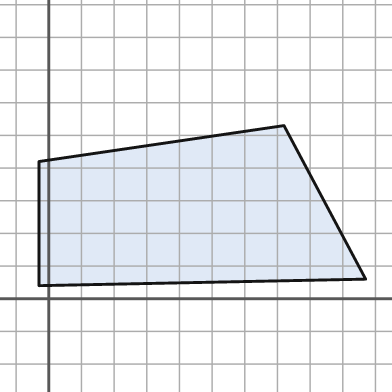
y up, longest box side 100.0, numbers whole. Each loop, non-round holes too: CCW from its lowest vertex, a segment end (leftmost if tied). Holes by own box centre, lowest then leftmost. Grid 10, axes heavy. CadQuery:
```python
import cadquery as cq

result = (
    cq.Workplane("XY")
    .moveTo(-3.0, 4.0)
    .lineTo(97.0, 6.0)
    .lineTo(72.0, 53.0)
    .lineTo(-3.0, 42.0)
    .close()
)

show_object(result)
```